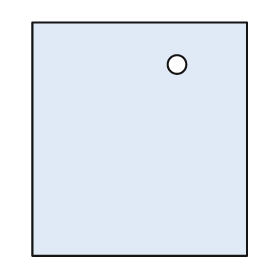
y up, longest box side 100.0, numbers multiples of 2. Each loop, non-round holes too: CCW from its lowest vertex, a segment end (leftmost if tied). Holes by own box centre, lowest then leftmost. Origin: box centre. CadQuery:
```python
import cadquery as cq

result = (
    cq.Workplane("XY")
    .moveTo(-46.0, -50.0)
    .lineTo(46.0, -50.0)
    .lineTo(46.0, 50.0)
    .lineTo(-46.0, 50.0)
    .close()
    .moveTo(16.0, 32.0)
    .circle(4.0)
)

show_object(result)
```